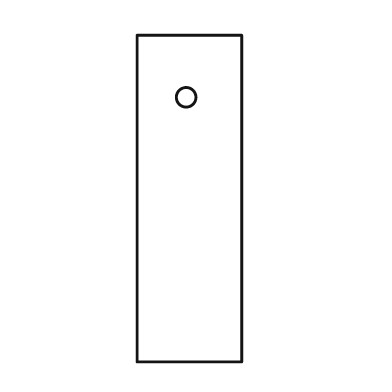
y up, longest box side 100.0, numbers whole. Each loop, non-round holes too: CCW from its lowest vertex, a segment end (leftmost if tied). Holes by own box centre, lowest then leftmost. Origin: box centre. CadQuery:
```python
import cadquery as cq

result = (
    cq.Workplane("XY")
    .moveTo(-16.0, -50.0)
    .lineTo(16.0, -50.0)
    .lineTo(16.0, 50.0)
    .lineTo(-16.0, 50.0)
    .close()
    .moveTo(-1.0, 31.0)
    .circle(3.0)
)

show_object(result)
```